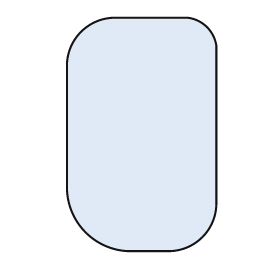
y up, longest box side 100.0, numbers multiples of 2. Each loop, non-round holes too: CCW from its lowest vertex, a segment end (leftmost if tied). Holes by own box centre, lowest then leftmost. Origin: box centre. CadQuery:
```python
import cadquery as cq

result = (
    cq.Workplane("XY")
    .moveTo(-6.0, -50.0)
    .lineTo(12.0, -50.0)
    .threePointArc((26.0, -44.0), (32.0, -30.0))
    .lineTo(32.0, 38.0)
    .threePointArc((28.0, 46.0), (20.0, 50.0))
    .lineTo(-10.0, 50.0)
    .threePointArc((-26.0, 44.0), (-32.0, 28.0))
    .lineTo(-32.0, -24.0)
    .threePointArc((-24.0, -42.0), (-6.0, -50.0))
    .close()
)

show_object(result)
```